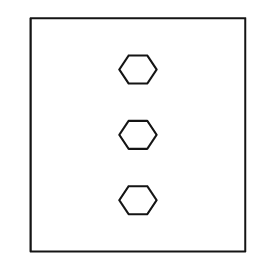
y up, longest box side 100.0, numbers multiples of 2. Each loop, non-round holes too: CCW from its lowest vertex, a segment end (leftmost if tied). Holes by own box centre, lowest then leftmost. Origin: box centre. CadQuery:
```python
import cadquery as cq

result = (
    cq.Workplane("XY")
    .moveTo(-46.0, -50.0)
    .lineTo(46.0, -50.0)
    .lineTo(46.0, 50.0)
    .lineTo(-46.0, 50.0)
    .close()
    .moveTo(-4.0, -34.0)
    .lineTo(4.0, -34.0)
    .lineTo(8.0, -28.0)
    .lineTo(4.0, -22.0)
    .lineTo(-4.0, -22.0)
    .lineTo(-8.0, -28.0)
    .close()
    .moveTo(-4.0, -6.0)
    .lineTo(4.0, -6.0)
    .lineTo(8.0, 0.0)
    .lineTo(4.0, 6.0)
    .lineTo(-4.0, 6.0)
    .lineTo(-8.0, 0.0)
    .close()
    .moveTo(-4.0, 22.0)
    .lineTo(4.0, 22.0)
    .lineTo(8.0, 28.0)
    .lineTo(4.0, 34.0)
    .lineTo(-4.0, 34.0)
    .lineTo(-8.0, 28.0)
    .close()
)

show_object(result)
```